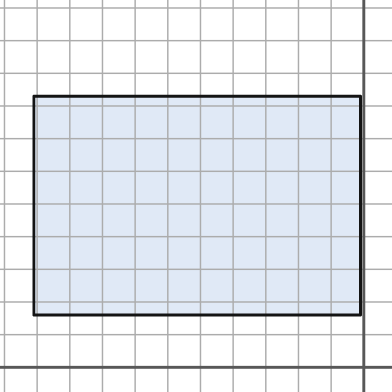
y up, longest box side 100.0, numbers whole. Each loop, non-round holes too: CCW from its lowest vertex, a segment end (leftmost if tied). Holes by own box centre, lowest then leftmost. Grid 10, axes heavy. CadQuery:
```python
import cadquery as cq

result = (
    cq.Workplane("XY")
    .moveTo(-101.0, 16.0)
    .lineTo(-1.0, 16.0)
    .lineTo(-1.0, 83.0)
    .lineTo(-101.0, 83.0)
    .close()
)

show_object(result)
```